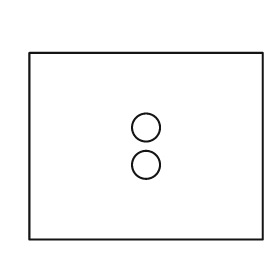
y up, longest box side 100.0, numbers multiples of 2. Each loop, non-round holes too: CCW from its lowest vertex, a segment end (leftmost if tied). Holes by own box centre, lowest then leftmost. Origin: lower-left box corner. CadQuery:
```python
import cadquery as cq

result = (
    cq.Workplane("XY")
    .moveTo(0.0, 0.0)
    .lineTo(100.0, 0.0)
    .lineTo(100.0, 80.0)
    .lineTo(0.0, 80.0)
    .close()
    .moveTo(50.0, 32.0)
    .circle(6.0)
    .moveTo(50.0, 48.0)
    .circle(6.0)
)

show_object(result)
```